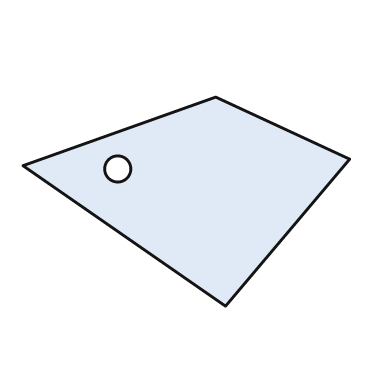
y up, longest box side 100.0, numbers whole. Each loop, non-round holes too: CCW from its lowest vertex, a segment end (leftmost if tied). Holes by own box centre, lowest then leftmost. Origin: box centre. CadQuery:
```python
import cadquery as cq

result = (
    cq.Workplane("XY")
    .moveTo(12.0, -32.0)
    .lineTo(50.0, 13.0)
    .lineTo(9.0, 32.0)
    .lineTo(-50.0, 11.0)
    .close()
    .moveTo(-21.0, 10.0)
    .circle(4.0)
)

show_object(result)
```